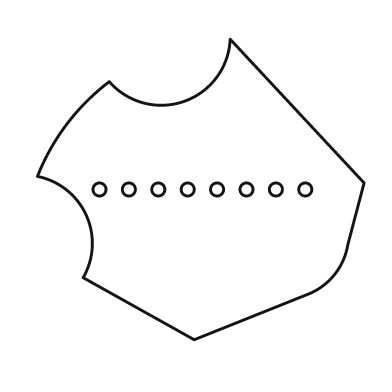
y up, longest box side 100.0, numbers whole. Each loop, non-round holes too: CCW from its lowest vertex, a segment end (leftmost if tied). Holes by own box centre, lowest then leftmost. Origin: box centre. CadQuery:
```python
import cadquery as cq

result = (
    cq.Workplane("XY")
    .moveTo(-2.0, -46.0)
    .lineTo(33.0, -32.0)
    .threePointArc((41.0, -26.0), (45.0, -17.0))
    .lineTo(50.0, 2.0)
    .lineTo(9.0, 46.0)
    .threePointArc((-5.0, 27.0), (-28.0, 33.0))
    .threePointArc((-41.0, 20.0), (-50.0, 4.0))
    .threePointArc((-35.0, -8.0), (-36.0, -27.0))
    .close()
    .moveTo(-31.0, 0.0)
    .circle(2.0)
    .moveTo(-22.0, 0.0)
    .circle(2.0)
    .moveTo(-13.0, 0.0)
    .circle(2.0)
    .moveTo(-4.0, 0.0)
    .circle(2.0)
    .moveTo(5.0, 0.0)
    .circle(2.0)
    .moveTo(14.0, 0.0)
    .circle(2.0)
    .moveTo(23.0, 0.0)
    .circle(2.0)
    .moveTo(32.0, 0.0)
    .circle(2.0)
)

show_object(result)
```